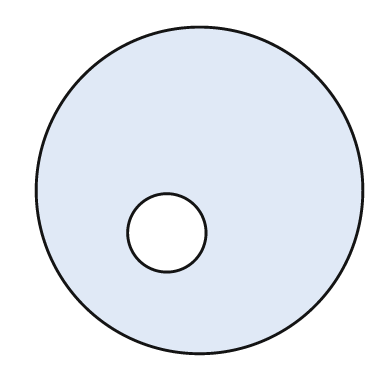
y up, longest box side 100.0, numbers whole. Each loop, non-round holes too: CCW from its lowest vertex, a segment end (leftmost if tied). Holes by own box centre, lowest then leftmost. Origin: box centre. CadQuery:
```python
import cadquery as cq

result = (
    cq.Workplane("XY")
    .moveTo(0.0, 0.0)
    .circle(50.0)
    .moveTo(-10.0, -13.0)
    .circle(12.0)
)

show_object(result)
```